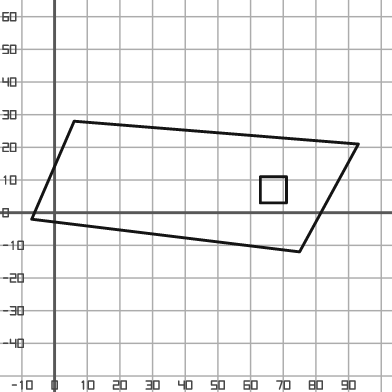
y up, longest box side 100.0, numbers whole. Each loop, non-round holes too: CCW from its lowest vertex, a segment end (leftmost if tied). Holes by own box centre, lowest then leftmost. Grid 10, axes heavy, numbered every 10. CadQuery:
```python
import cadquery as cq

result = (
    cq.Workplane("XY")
    .moveTo(75.0, -12.0)
    .lineTo(93.0, 21.0)
    .lineTo(6.0, 28.0)
    .lineTo(-7.0, -2.0)
    .close()
    .moveTo(63.0, 3.0)
    .lineTo(71.0, 3.0)
    .lineTo(71.0, 11.0)
    .lineTo(63.0, 11.0)
    .close()
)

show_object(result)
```